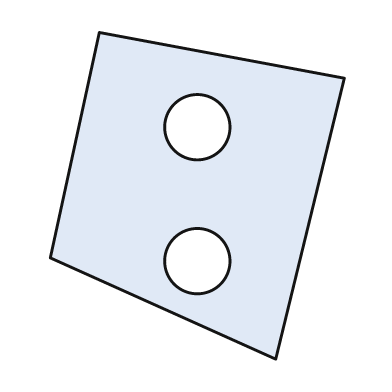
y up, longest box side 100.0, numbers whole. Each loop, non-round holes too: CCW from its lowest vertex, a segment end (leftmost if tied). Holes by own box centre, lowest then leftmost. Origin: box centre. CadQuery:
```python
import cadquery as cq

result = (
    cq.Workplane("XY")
    .moveTo(24.0, -50.0)
    .lineTo(45.0, 36.0)
    .lineTo(-30.0, 50.0)
    .lineTo(-45.0, -19.0)
    .close()
    .moveTo(0.0, -20.0)
    .circle(10.0)
    .moveTo(0.0, 21.0)
    .circle(10.0)
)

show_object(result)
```